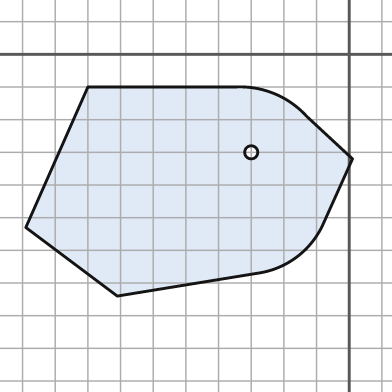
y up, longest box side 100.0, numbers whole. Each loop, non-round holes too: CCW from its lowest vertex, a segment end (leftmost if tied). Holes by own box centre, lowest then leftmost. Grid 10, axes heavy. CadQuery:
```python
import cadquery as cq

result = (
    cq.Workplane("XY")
    .moveTo(-71.0, -74.0)
    .lineTo(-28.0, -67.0)
    .threePointArc((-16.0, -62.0), (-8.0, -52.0))
    .lineTo(1.0, -32.0)
    .lineTo(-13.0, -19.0)
    .threePointArc((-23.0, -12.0), (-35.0, -10.0))
    .lineTo(-80.0, -10.0)
    .lineTo(-99.0, -53.0)
    .close()
    .moveTo(-30.0, -30.0)
    .circle(2.0)
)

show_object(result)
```